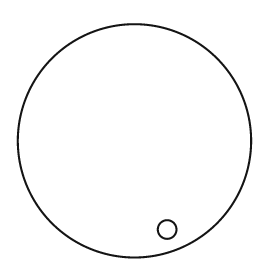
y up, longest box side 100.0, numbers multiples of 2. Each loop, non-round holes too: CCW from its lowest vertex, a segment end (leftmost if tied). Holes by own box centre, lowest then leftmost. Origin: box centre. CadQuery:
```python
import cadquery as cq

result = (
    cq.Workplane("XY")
    .moveTo(0.0, 0.0)
    .circle(50.0)
    .moveTo(14.0, -38.0)
    .circle(4.0)
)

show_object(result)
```